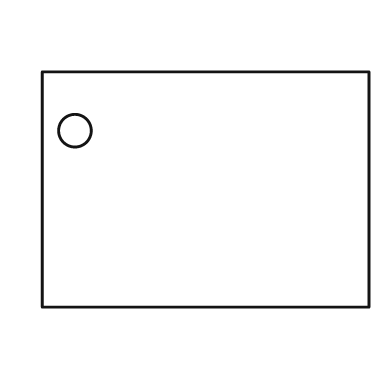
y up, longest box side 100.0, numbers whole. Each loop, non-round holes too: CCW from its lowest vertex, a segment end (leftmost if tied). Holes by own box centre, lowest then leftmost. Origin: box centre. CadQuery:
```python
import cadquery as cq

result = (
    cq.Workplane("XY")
    .moveTo(-50.0, -36.0)
    .lineTo(50.0, -36.0)
    .lineTo(50.0, 36.0)
    .lineTo(-50.0, 36.0)
    .close()
    .moveTo(-40.0, 18.0)
    .circle(5.0)
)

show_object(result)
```